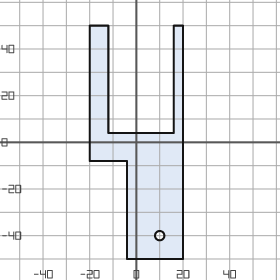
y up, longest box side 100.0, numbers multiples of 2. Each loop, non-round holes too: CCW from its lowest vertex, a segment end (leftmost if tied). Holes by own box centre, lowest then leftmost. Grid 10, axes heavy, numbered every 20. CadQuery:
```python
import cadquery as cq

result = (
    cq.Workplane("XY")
    .moveTo(-4.0, -50.0)
    .lineTo(20.0, -50.0)
    .lineTo(20.0, 50.0)
    .lineTo(16.0, 50.0)
    .lineTo(16.0, 4.0)
    .lineTo(-12.0, 4.0)
    .lineTo(-12.0, 50.0)
    .lineTo(-20.0, 50.0)
    .lineTo(-20.0, -8.0)
    .lineTo(-4.0, -8.0)
    .close()
    .moveTo(10.0, -40.0)
    .circle(2.0)
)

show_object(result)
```